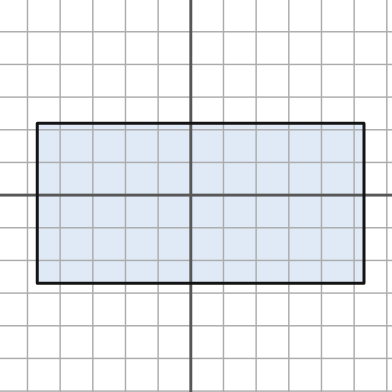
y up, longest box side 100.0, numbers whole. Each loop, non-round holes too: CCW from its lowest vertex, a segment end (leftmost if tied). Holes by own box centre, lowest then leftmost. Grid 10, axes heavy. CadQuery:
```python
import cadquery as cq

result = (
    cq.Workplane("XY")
    .moveTo(-47.0, -27.0)
    .lineTo(53.0, -27.0)
    .lineTo(53.0, 22.0)
    .lineTo(-47.0, 22.0)
    .close()
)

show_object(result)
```